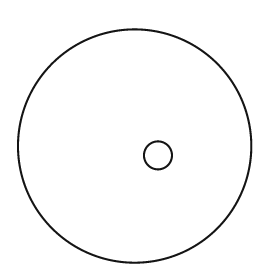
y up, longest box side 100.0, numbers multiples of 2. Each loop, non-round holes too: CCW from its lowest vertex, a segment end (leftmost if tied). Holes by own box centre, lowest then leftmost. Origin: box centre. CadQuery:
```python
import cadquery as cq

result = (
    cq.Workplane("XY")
    .moveTo(0.0, 0.0)
    .circle(50.0)
    .moveTo(10.0, -4.0)
    .circle(6.0)
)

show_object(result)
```